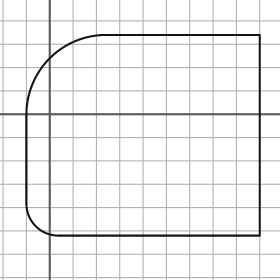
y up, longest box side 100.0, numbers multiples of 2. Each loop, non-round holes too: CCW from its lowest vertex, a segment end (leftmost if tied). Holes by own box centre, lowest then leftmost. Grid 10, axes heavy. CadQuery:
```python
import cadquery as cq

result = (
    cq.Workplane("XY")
    .moveTo(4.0, -52.0)
    .lineTo(90.0, -52.0)
    .lineTo(90.0, 34.0)
    .lineTo(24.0, 34.0)
    .threePointArc((0.0, 24.0), (-10.0, 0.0))
    .lineTo(-10.0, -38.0)
    .threePointArc((-6.0, -48.0), (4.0, -52.0))
    .close()
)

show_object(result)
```